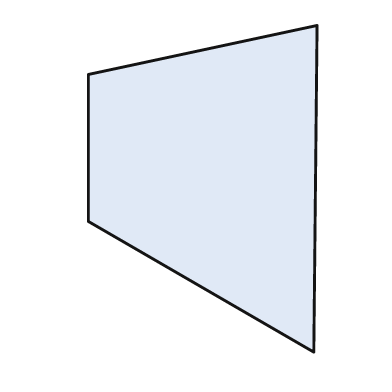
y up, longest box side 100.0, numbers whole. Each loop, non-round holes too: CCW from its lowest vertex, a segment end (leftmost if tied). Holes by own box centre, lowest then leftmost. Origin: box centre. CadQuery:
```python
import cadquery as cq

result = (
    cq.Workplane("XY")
    .moveTo(34.0, -50.0)
    .lineTo(35.0, 50.0)
    .lineTo(-35.0, 35.0)
    .lineTo(-35.0, -10.0)
    .close()
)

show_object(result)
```